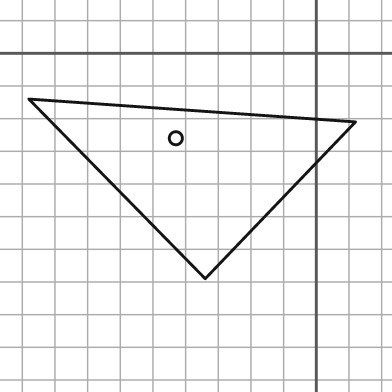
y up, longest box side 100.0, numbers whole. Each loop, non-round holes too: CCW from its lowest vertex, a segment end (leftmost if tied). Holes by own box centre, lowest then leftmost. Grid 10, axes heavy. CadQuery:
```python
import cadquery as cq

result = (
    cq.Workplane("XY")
    .moveTo(-34.0, -69.0)
    .lineTo(12.0, -21.0)
    .lineTo(-88.0, -14.0)
    .close()
    .moveTo(-43.0, -26.0)
    .circle(2.0)
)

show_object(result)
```